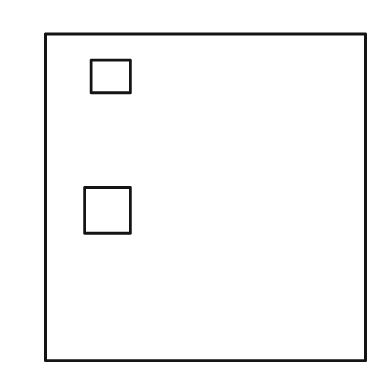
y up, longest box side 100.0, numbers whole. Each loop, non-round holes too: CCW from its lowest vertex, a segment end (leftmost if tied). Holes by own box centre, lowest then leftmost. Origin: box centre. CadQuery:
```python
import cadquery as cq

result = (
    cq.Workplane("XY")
    .moveTo(-49.0, -50.0)
    .lineTo(49.0, -50.0)
    .lineTo(49.0, 50.0)
    .lineTo(-49.0, 50.0)
    .close()
    .moveTo(-37.0, -11.0)
    .lineTo(-23.0, -11.0)
    .lineTo(-23.0, 3.0)
    .lineTo(-37.0, 3.0)
    .close()
    .moveTo(-35.0, 32.0)
    .lineTo(-23.0, 32.0)
    .lineTo(-23.0, 42.0)
    .lineTo(-35.0, 42.0)
    .close()
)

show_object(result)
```